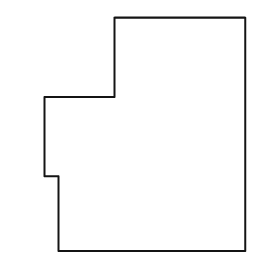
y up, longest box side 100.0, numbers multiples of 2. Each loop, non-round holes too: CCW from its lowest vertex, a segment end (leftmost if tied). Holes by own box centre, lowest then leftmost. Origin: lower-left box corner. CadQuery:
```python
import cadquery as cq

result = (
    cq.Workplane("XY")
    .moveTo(6.0, 0.0)
    .lineTo(86.0, 0.0)
    .lineTo(86.0, 100.0)
    .lineTo(30.0, 100.0)
    .lineTo(30.0, 66.0)
    .lineTo(0.0, 66.0)
    .lineTo(0.0, 32.0)
    .lineTo(6.0, 32.0)
    .close()
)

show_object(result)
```